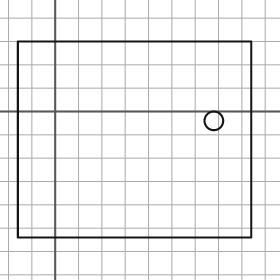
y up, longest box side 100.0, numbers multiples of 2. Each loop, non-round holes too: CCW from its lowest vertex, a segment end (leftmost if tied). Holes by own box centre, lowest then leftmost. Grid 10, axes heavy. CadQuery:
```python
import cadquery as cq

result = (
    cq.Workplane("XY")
    .moveTo(-16.0, -54.0)
    .lineTo(84.0, -54.0)
    .lineTo(84.0, 30.0)
    .lineTo(-16.0, 30.0)
    .close()
    .moveTo(68.0, -4.0)
    .circle(4.0)
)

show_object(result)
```